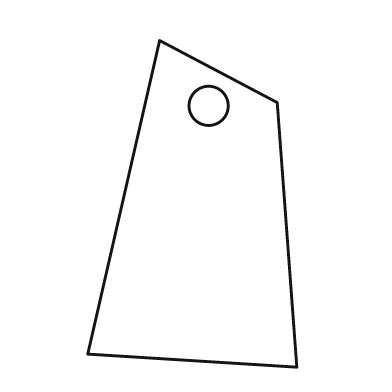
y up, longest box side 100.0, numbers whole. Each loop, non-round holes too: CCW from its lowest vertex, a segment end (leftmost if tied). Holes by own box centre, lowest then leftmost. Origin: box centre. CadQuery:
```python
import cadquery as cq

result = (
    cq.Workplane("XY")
    .moveTo(32.0, -50.0)
    .lineTo(26.0, 31.0)
    .lineTo(-10.0, 50.0)
    .lineTo(-32.0, -46.0)
    .close()
    .moveTo(5.0, 30.0)
    .circle(6.0)
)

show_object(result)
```